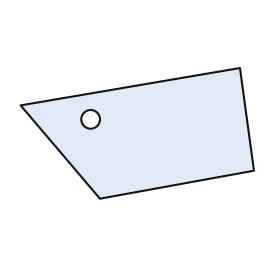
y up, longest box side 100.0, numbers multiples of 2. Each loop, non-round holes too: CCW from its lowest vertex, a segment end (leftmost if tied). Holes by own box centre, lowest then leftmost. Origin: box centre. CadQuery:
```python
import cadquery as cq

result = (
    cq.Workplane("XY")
    .moveTo(-16.0, -28.0)
    .lineTo(50.0, -16.0)
    .lineTo(44.0, 28.0)
    .lineTo(-50.0, 12.0)
    .close()
    .moveTo(-20.0, 6.0)
    .circle(4.0)
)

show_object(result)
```